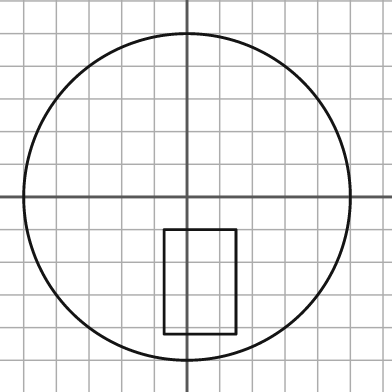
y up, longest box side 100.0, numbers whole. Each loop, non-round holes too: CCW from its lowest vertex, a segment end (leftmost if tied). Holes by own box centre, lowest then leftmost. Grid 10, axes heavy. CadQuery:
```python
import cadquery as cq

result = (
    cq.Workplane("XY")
    .moveTo(0.0, 0.0)
    .circle(50.0)
    .moveTo(-7.0, -42.0)
    .lineTo(15.0, -42.0)
    .lineTo(15.0, -10.0)
    .lineTo(-7.0, -10.0)
    .close()
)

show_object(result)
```